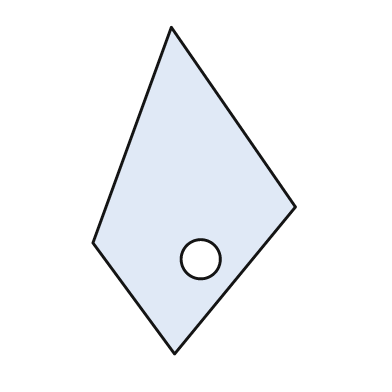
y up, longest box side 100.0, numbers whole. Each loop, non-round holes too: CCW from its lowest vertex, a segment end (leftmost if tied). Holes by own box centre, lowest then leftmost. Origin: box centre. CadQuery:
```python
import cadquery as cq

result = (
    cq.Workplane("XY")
    .moveTo(-6.0, -50.0)
    .lineTo(31.0, -5.0)
    .lineTo(-7.0, 50.0)
    .lineTo(-31.0, -16.0)
    .close()
    .moveTo(2.0, -21.0)
    .circle(6.0)
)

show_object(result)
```